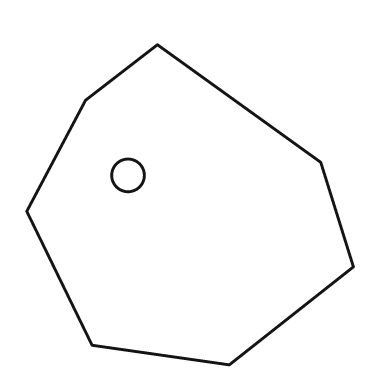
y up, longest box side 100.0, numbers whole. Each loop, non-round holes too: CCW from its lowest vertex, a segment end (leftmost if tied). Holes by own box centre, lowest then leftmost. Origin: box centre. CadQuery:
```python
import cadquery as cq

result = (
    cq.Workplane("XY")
    .moveTo(12.0, -49.0)
    .lineTo(50.0, -19.0)
    .lineTo(40.0, 13.0)
    .lineTo(-10.0, 49.0)
    .lineTo(-32.0, 32.0)
    .lineTo(-50.0, -2.0)
    .lineTo(-30.0, -43.0)
    .close()
    .moveTo(-19.0, 9.0)
    .circle(5.0)
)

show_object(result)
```